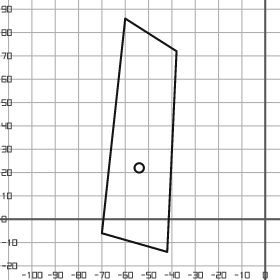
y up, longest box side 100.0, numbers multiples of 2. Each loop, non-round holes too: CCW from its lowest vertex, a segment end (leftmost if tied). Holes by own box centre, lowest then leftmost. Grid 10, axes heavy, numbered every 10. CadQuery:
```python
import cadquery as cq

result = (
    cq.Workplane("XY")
    .moveTo(-42.0, -14.0)
    .lineTo(-38.0, 72.0)
    .lineTo(-60.0, 86.0)
    .lineTo(-70.0, -6.0)
    .close()
    .moveTo(-54.0, 22.0)
    .circle(2.0)
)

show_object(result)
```